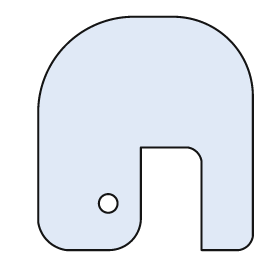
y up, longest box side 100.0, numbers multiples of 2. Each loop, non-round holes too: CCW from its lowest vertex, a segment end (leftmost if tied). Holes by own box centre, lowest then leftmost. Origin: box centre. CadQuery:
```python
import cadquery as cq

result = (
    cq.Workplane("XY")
    .moveTo(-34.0, -50.0)
    .lineTo(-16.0, -50.0)
    .threePointArc((-6.0, -46.0), (-2.0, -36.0))
    .lineTo(-2.0, -6.0)
    .lineTo(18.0, -6.0)
    .threePointArc((22.0, -8.0), (24.0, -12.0))
    .lineTo(24.0, -50.0)
    .lineTo(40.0, -50.0)
    .threePointArc((44.0, -48.0), (46.0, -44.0))
    .lineTo(46.0, 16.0)
    .threePointArc((36.0, 40.0), (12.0, 50.0))
    .lineTo(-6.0, 50.0)
    .threePointArc((-34.0, 38.0), (-46.0, 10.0))
    .lineTo(-46.0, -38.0)
    .threePointArc((-42.0, -46.0), (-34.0, -50.0))
    .close()
    .moveTo(-16.0, -30.0)
    .circle(4.0)
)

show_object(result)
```